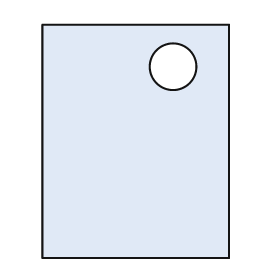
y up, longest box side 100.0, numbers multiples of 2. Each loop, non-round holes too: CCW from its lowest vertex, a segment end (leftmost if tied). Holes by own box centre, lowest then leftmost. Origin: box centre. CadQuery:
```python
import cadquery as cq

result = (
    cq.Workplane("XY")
    .moveTo(-40.0, -50.0)
    .lineTo(40.0, -50.0)
    .lineTo(40.0, 50.0)
    .lineTo(-40.0, 50.0)
    .close()
    .moveTo(16.0, 32.0)
    .circle(10.0)
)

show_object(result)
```